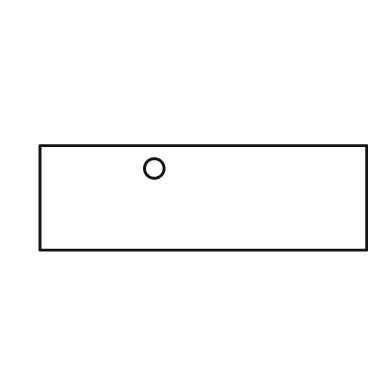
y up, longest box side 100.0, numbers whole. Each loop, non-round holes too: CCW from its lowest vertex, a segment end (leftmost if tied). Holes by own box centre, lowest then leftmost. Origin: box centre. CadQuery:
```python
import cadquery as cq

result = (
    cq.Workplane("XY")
    .moveTo(-50.0, -16.0)
    .lineTo(50.0, -16.0)
    .lineTo(50.0, 16.0)
    .lineTo(-50.0, 16.0)
    .close()
    .moveTo(-15.0, 9.0)
    .circle(3.0)
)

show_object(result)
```